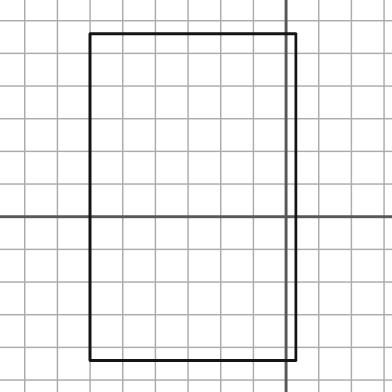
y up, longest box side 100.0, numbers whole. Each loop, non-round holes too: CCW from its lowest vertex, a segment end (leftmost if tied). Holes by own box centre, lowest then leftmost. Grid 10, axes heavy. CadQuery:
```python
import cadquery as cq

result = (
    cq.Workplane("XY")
    .moveTo(-60.0, -44.0)
    .lineTo(3.0, -44.0)
    .lineTo(3.0, 56.0)
    .lineTo(-60.0, 56.0)
    .close()
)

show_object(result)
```